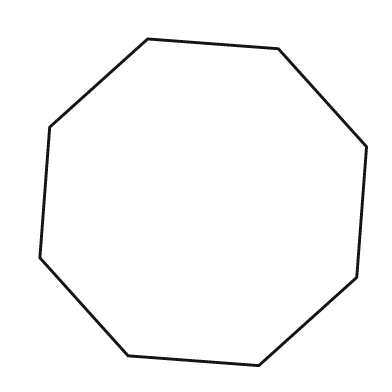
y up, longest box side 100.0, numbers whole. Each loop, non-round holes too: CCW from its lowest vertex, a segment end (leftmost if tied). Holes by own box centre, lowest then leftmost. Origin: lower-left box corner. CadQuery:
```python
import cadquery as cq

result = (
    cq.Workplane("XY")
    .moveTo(67.0, 0.0)
    .lineTo(97.0, 27.0)
    .lineTo(100.0, 67.0)
    .lineTo(73.0, 97.0)
    .lineTo(33.0, 100.0)
    .lineTo(3.0, 73.0)
    .lineTo(0.0, 33.0)
    .lineTo(27.0, 3.0)
    .close()
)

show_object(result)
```